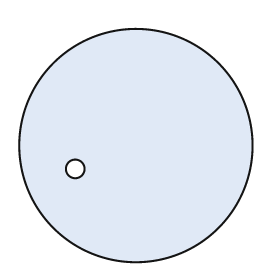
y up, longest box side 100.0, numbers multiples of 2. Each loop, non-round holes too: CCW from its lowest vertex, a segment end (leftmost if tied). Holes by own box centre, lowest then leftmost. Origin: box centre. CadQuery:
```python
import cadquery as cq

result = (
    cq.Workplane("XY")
    .moveTo(0.0, 0.0)
    .circle(50.0)
    .moveTo(-26.0, -10.0)
    .circle(4.0)
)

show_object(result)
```